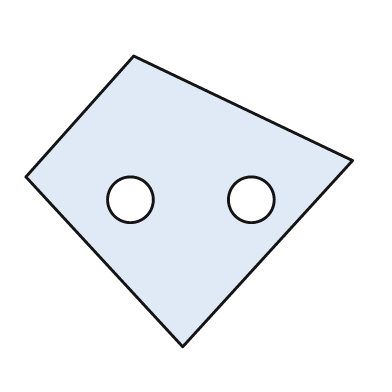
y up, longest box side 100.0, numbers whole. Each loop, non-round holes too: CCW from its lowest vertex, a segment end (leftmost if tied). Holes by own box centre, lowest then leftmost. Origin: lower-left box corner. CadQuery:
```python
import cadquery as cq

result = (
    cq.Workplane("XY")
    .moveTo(48.0, 0.0)
    .lineTo(100.0, 57.0)
    .lineTo(33.0, 89.0)
    .lineTo(0.0, 52.0)
    .close()
    .moveTo(32.0, 45.0)
    .circle(7.0)
    .moveTo(69.0, 45.0)
    .circle(7.0)
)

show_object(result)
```